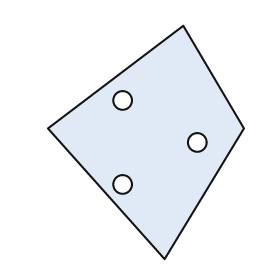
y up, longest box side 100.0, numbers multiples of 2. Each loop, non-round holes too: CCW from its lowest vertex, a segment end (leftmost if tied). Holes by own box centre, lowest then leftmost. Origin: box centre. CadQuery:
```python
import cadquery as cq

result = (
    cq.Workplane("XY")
    .moveTo(8.0, -50.0)
    .lineTo(42.0, 6.0)
    .lineTo(16.0, 50.0)
    .lineTo(-42.0, 6.0)
    .close()
    .moveTo(-10.0, -18.0)
    .circle(4.0)
    .moveTo(22.0, 0.0)
    .circle(4.0)
    .moveTo(-10.0, 18.0)
    .circle(4.0)
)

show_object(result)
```